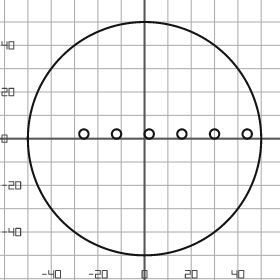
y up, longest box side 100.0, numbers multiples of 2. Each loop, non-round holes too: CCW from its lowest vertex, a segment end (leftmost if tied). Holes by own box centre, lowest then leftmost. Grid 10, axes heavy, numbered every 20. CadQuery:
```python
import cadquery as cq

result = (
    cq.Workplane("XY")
    .moveTo(0.0, 0.0)
    .circle(50.0)
    .moveTo(-26.0, 2.0)
    .circle(2.0)
    .moveTo(-12.0, 2.0)
    .circle(2.0)
    .moveTo(2.0, 2.0)
    .circle(2.0)
    .moveTo(16.0, 2.0)
    .circle(2.0)
    .moveTo(30.0, 2.0)
    .circle(2.0)
    .moveTo(44.0, 2.0)
    .circle(2.0)
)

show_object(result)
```